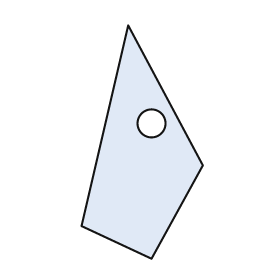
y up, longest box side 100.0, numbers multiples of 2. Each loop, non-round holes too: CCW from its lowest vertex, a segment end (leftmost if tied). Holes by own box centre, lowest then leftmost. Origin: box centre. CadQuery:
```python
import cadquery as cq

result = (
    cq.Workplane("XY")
    .moveTo(4.0, -50.0)
    .lineTo(26.0, -10.0)
    .lineTo(-6.0, 50.0)
    .lineTo(-26.0, -36.0)
    .close()
    .moveTo(4.0, 8.0)
    .circle(6.0)
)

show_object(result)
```